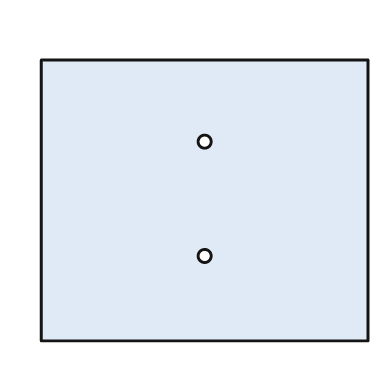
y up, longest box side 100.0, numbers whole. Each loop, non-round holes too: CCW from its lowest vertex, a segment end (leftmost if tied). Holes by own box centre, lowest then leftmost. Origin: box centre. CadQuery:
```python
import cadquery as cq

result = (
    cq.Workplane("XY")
    .moveTo(-50.0, -43.0)
    .lineTo(50.0, -43.0)
    .lineTo(50.0, 43.0)
    .lineTo(-50.0, 43.0)
    .close()
    .moveTo(0.0, -17.0)
    .circle(2.0)
    .moveTo(0.0, 18.0)
    .circle(2.0)
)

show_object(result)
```